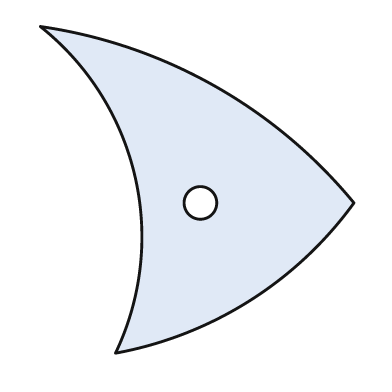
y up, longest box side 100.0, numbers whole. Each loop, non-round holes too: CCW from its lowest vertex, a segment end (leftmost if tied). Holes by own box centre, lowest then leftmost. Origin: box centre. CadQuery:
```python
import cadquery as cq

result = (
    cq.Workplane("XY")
    .moveTo(-25.0, -50.0)
    .threePointArc((16.0, -34.0), (48.0, -4.0))
    .threePointArc((5.0, 32.0), (-48.0, 50.0))
    .threePointArc((-19.0, 4.0), (-25.0, -50.0))
    .close()
    .moveTo(1.0, -4.0)
    .circle(5.0)
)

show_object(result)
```